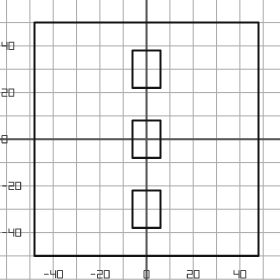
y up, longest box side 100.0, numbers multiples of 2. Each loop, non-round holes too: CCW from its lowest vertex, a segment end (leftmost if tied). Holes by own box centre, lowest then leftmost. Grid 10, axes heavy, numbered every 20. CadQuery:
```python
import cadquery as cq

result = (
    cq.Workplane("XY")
    .moveTo(-48.0, -50.0)
    .lineTo(48.0, -50.0)
    .lineTo(48.0, 50.0)
    .lineTo(-48.0, 50.0)
    .close()
    .moveTo(-6.0, -38.0)
    .lineTo(6.0, -38.0)
    .lineTo(6.0, -22.0)
    .lineTo(-6.0, -22.0)
    .close()
    .moveTo(-6.0, -8.0)
    .lineTo(6.0, -8.0)
    .lineTo(6.0, 8.0)
    .lineTo(-6.0, 8.0)
    .close()
    .moveTo(-6.0, 22.0)
    .lineTo(6.0, 22.0)
    .lineTo(6.0, 38.0)
    .lineTo(-6.0, 38.0)
    .close()
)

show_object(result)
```